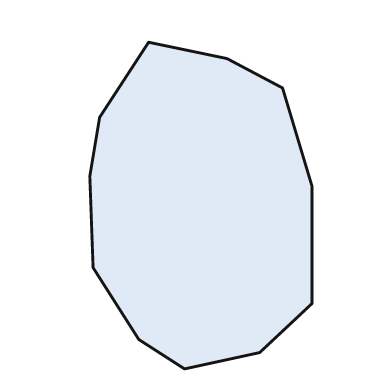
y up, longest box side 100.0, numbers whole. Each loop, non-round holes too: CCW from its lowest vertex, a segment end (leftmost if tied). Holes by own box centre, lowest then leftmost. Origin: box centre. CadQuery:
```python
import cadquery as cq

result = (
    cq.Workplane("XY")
    .moveTo(-5.0, -50.0)
    .lineTo(18.0, -45.0)
    .lineTo(34.0, -30.0)
    .lineTo(34.0, 6.0)
    .lineTo(25.0, 36.0)
    .lineTo(8.0, 45.0)
    .lineTo(-16.0, 50.0)
    .lineTo(-31.0, 27.0)
    .lineTo(-34.0, 9.0)
    .lineTo(-33.0, -19.0)
    .lineTo(-19.0, -41.0)
    .close()
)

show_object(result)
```